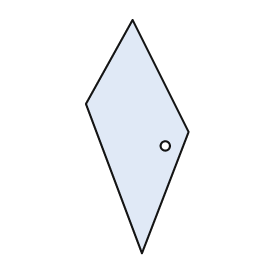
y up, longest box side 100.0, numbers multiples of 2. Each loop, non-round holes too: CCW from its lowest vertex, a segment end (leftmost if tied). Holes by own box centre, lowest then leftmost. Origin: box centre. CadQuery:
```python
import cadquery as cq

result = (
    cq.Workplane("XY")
    .moveTo(2.0, -50.0)
    .lineTo(22.0, 2.0)
    .lineTo(-2.0, 50.0)
    .lineTo(-22.0, 14.0)
    .close()
    .moveTo(12.0, -4.0)
    .circle(2.0)
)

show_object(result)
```